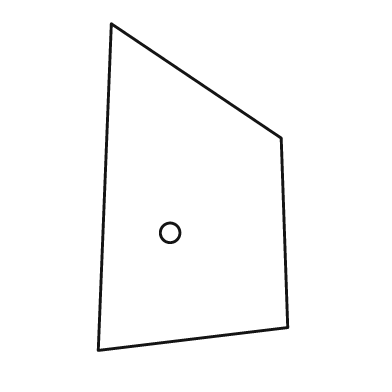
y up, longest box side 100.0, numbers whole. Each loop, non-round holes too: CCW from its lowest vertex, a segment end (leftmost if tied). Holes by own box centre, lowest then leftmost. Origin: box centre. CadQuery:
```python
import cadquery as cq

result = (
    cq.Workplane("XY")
    .moveTo(-29.0, -50.0)
    .lineTo(29.0, -43.0)
    .lineTo(27.0, 15.0)
    .lineTo(-25.0, 50.0)
    .close()
    .moveTo(-7.0, -14.0)
    .circle(3.0)
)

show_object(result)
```